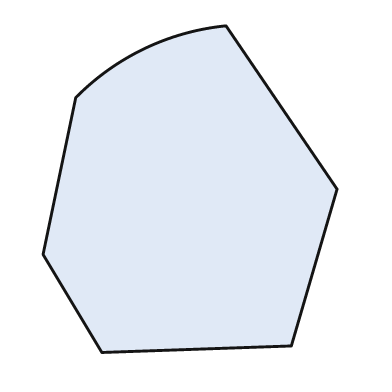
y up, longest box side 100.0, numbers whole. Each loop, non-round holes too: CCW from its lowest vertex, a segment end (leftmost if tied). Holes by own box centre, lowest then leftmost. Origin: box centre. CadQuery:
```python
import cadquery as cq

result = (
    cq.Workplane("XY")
    .moveTo(-27.0, -50.0)
    .lineTo(31.0, -48.0)
    .lineTo(45.0, 0.0)
    .lineTo(11.0, 50.0)
    .threePointArc((-14.0, 43.0), (-35.0, 28.0))
    .lineTo(-45.0, -20.0)
    .close()
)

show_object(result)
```